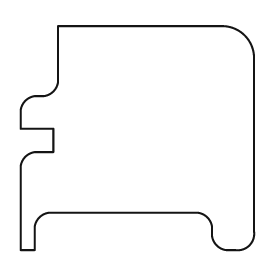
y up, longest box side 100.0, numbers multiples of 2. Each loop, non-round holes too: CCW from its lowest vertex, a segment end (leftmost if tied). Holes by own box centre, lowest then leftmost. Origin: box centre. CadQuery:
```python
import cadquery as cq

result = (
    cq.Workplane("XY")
    .moveTo(-50.0, -48.0)
    .lineTo(-44.0, -48.0)
    .lineTo(-44.0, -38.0)
    .threePointArc((-42.0, -34.0), (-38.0, -32.0))
    .lineTo(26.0, -32.0)
    .threePointArc((30.0, -34.0), (32.0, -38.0))
    .lineTo(32.0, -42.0)
    .threePointArc((34.0, -46.0), (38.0, -48.0))
    .lineTo(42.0, -48.0)
    .threePointArc((48.0, -46.0), (50.0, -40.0))
    .lineTo(50.0, 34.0)
    .threePointArc((46.0, 44.0), (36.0, 48.0))
    .lineTo(-34.0, 48.0)
    .lineTo(-34.0, 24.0)
    .threePointArc((-36.0, 20.0), (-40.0, 18.0))
    .lineTo(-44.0, 18.0)
    .threePointArc((-48.0, 16.0), (-50.0, 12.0))
    .lineTo(-50.0, 4.0)
    .lineTo(-36.0, 4.0)
    .lineTo(-36.0, -6.0)
    .lineTo(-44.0, -6.0)
    .threePointArc((-48.0, -8.0), (-50.0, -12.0))
    .close()
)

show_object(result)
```